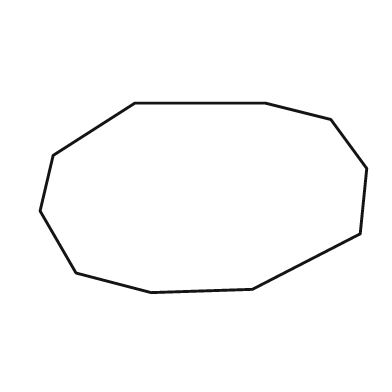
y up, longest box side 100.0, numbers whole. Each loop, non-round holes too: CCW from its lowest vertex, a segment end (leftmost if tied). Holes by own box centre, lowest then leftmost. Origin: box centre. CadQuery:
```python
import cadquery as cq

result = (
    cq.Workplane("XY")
    .moveTo(-16.0, -29.0)
    .lineTo(15.0, -28.0)
    .lineTo(48.0, -11.0)
    .lineTo(50.0, 9.0)
    .lineTo(39.0, 24.0)
    .lineTo(19.0, 29.0)
    .lineTo(-21.0, 29.0)
    .lineTo(-46.0, 13.0)
    .lineTo(-50.0, -4.0)
    .lineTo(-39.0, -23.0)
    .close()
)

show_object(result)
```